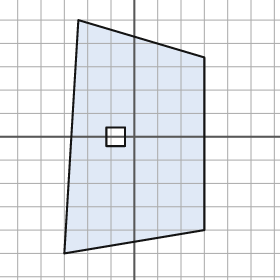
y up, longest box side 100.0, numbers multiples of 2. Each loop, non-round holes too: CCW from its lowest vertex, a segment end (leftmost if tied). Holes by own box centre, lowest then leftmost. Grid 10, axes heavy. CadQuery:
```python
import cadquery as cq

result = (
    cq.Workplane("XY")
    .moveTo(-30.0, -50.0)
    .lineTo(30.0, -40.0)
    .lineTo(30.0, 34.0)
    .lineTo(-24.0, 50.0)
    .close()
    .moveTo(-12.0, -4.0)
    .lineTo(-4.0, -4.0)
    .lineTo(-4.0, 4.0)
    .lineTo(-12.0, 4.0)
    .close()
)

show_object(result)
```